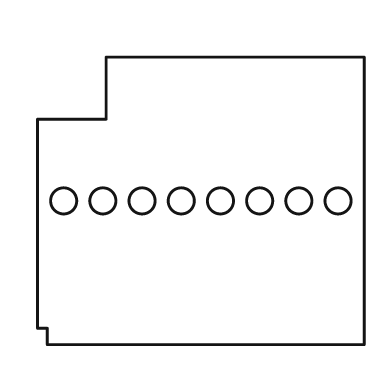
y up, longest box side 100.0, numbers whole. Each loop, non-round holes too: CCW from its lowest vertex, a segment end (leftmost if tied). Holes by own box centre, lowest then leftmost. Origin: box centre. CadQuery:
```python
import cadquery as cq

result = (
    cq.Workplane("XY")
    .moveTo(-47.0, -44.0)
    .lineTo(50.0, -44.0)
    .lineTo(50.0, 44.0)
    .lineTo(-29.0, 44.0)
    .lineTo(-29.0, 25.0)
    .lineTo(-50.0, 25.0)
    .lineTo(-50.0, -39.0)
    .lineTo(-47.0, -39.0)
    .close()
    .moveTo(-42.0, 0.0)
    .circle(4.0)
    .moveTo(-30.0, 0.0)
    .circle(4.0)
    .moveTo(-18.0, 0.0)
    .circle(4.0)
    .moveTo(-6.0, 0.0)
    .circle(4.0)
    .moveTo(6.0, 0.0)
    .circle(4.0)
    .moveTo(18.0, 0.0)
    .circle(4.0)
    .moveTo(30.0, 0.0)
    .circle(4.0)
    .moveTo(42.0, 0.0)
    .circle(4.0)
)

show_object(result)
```